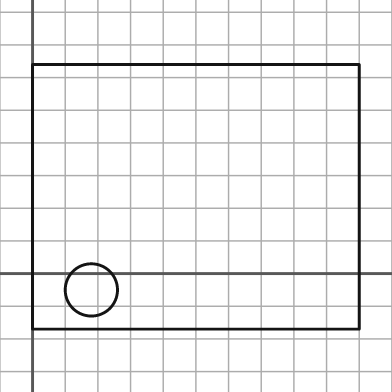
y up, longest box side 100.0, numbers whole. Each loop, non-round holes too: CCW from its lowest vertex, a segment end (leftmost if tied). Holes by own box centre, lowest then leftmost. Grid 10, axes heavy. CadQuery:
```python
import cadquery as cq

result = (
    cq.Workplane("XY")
    .moveTo(0.0, -17.0)
    .lineTo(100.0, -17.0)
    .lineTo(100.0, 64.0)
    .lineTo(0.0, 64.0)
    .close()
    .moveTo(18.0, -5.0)
    .circle(8.0)
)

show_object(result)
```